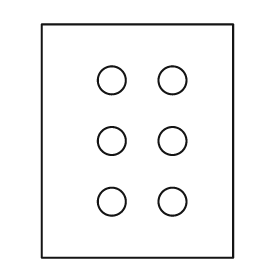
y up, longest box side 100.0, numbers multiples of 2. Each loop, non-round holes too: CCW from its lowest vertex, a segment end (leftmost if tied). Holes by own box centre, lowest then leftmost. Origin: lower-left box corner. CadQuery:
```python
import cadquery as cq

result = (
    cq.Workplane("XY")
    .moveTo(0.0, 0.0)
    .lineTo(82.0, 0.0)
    .lineTo(82.0, 100.0)
    .lineTo(0.0, 100.0)
    .close()
    .moveTo(30.0, 24.0)
    .circle(6.0)
    .moveTo(56.0, 24.0)
    .circle(6.0)
    .moveTo(30.0, 50.0)
    .circle(6.0)
    .moveTo(56.0, 50.0)
    .circle(6.0)
    .moveTo(30.0, 76.0)
    .circle(6.0)
    .moveTo(56.0, 76.0)
    .circle(6.0)
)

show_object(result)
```